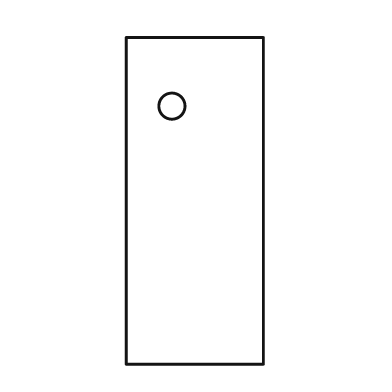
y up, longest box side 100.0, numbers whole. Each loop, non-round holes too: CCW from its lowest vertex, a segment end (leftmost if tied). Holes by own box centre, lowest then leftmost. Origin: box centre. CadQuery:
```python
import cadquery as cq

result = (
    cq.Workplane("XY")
    .moveTo(-21.0, -50.0)
    .lineTo(21.0, -50.0)
    .lineTo(21.0, 50.0)
    .lineTo(-21.0, 50.0)
    .close()
    .moveTo(-7.0, 29.0)
    .circle(4.0)
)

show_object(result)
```